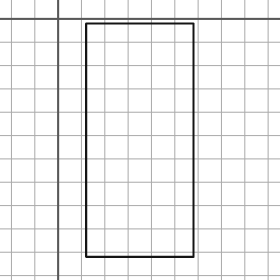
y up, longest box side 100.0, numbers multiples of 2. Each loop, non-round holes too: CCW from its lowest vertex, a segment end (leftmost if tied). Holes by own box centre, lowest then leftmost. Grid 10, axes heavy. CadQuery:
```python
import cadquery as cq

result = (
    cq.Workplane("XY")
    .moveTo(12.0, -102.0)
    .lineTo(58.0, -102.0)
    .lineTo(58.0, -2.0)
    .lineTo(12.0, -2.0)
    .close()
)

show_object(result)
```